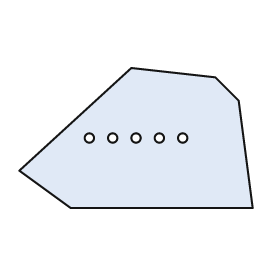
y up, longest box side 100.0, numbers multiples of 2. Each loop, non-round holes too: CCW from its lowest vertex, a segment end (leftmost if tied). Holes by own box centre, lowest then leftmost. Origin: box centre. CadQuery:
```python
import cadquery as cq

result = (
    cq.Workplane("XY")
    .moveTo(-28.0, -30.0)
    .lineTo(50.0, -30.0)
    .lineTo(44.0, 16.0)
    .lineTo(34.0, 26.0)
    .lineTo(-2.0, 30.0)
    .lineTo(-50.0, -14.0)
    .close()
    .moveTo(-20.0, 0.0)
    .circle(2.0)
    .moveTo(-10.0, 0.0)
    .circle(2.0)
    .moveTo(0.0, 0.0)
    .circle(2.0)
    .moveTo(10.0, 0.0)
    .circle(2.0)
    .moveTo(20.0, 0.0)
    .circle(2.0)
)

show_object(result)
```